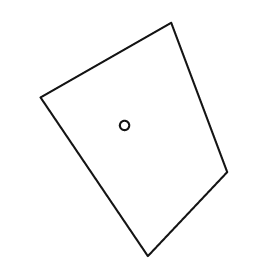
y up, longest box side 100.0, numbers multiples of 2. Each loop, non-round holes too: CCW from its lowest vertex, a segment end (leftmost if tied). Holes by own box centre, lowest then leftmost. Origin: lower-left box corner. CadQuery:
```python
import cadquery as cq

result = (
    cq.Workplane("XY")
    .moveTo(46.0, 0.0)
    .lineTo(80.0, 36.0)
    .lineTo(56.0, 100.0)
    .lineTo(0.0, 68.0)
    .close()
    .moveTo(36.0, 56.0)
    .circle(2.0)
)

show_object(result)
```